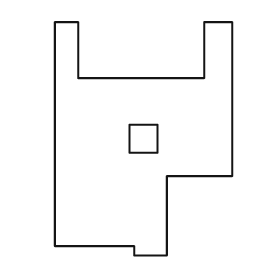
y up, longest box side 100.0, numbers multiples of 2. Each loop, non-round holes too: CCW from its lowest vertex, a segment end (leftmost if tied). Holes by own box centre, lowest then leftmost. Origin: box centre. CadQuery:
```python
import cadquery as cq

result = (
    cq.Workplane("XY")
    .moveTo(-4.0, -50.0)
    .lineTo(10.0, -50.0)
    .lineTo(10.0, -16.0)
    .lineTo(38.0, -16.0)
    .lineTo(38.0, 50.0)
    .lineTo(26.0, 50.0)
    .lineTo(26.0, 26.0)
    .lineTo(-28.0, 26.0)
    .lineTo(-28.0, 50.0)
    .lineTo(-38.0, 50.0)
    .lineTo(-38.0, -46.0)
    .lineTo(-4.0, -46.0)
    .close()
    .moveTo(-6.0, -6.0)
    .lineTo(6.0, -6.0)
    .lineTo(6.0, 6.0)
    .lineTo(-6.0, 6.0)
    .close()
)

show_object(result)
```